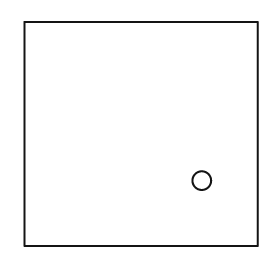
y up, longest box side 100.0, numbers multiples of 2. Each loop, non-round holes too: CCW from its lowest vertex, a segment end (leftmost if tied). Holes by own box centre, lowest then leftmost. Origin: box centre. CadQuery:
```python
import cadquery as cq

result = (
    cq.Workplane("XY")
    .moveTo(-50.0, -48.0)
    .lineTo(50.0, -48.0)
    .lineTo(50.0, 48.0)
    .lineTo(-50.0, 48.0)
    .close()
    .moveTo(26.0, -20.0)
    .circle(4.0)
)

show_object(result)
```